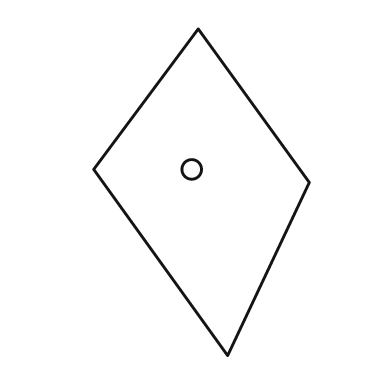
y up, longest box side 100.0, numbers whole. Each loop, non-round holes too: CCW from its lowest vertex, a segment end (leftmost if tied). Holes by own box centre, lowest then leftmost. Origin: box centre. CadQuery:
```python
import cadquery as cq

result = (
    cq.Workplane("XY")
    .moveTo(8.0, -50.0)
    .lineTo(33.0, 3.0)
    .lineTo(-1.0, 50.0)
    .lineTo(-33.0, 7.0)
    .close()
    .moveTo(-3.0, 7.0)
    .circle(3.0)
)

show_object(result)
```